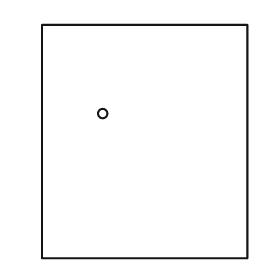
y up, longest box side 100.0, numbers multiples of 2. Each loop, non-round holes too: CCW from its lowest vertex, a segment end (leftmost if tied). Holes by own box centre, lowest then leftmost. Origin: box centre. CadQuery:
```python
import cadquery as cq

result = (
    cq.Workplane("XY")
    .moveTo(-44.0, -50.0)
    .lineTo(44.0, -50.0)
    .lineTo(44.0, 50.0)
    .lineTo(-44.0, 50.0)
    .close()
    .moveTo(-18.0, 12.0)
    .circle(2.0)
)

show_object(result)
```